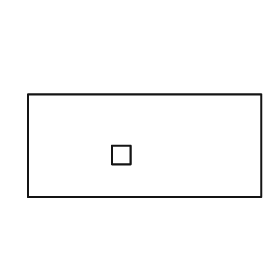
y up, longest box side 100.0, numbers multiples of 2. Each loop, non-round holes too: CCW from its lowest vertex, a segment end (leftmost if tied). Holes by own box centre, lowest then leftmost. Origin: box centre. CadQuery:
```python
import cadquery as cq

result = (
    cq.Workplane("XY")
    .moveTo(-50.0, -22.0)
    .lineTo(50.0, -22.0)
    .lineTo(50.0, 22.0)
    .lineTo(-50.0, 22.0)
    .close()
    .moveTo(-14.0, -8.0)
    .lineTo(-6.0, -8.0)
    .lineTo(-6.0, 0.0)
    .lineTo(-14.0, 0.0)
    .close()
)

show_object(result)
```